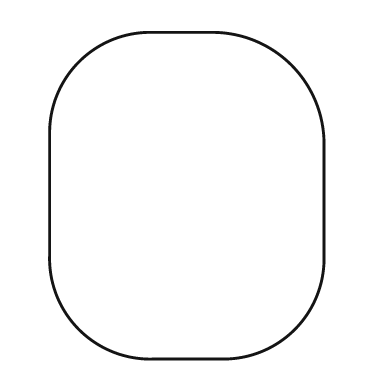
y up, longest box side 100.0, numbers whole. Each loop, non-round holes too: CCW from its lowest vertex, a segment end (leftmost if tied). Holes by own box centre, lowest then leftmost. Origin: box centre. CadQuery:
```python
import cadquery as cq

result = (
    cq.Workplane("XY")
    .moveTo(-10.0, -50.0)
    .lineTo(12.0, -50.0)
    .threePointArc((33.0, -41.0), (42.0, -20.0))
    .lineTo(42.0, 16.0)
    .threePointArc((32.0, 40.0), (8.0, 50.0))
    .lineTo(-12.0, 50.0)
    .threePointArc((-33.0, 41.0), (-42.0, 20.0))
    .lineTo(-42.0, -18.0)
    .threePointArc((-33.0, -41.0), (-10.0, -50.0))
    .close()
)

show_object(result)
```